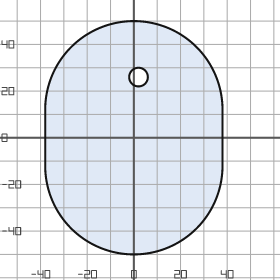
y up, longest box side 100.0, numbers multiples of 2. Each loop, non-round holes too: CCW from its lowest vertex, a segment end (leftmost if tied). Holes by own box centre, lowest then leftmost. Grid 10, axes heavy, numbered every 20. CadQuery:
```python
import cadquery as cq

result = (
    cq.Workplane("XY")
    .moveTo(-38.0, -12.0)
    .threePointArc((0.0, -50.0), (38.0, -12.0))
    .lineTo(38.0, 12.0)
    .threePointArc((0.0, 50.0), (-38.0, 12.0))
    .close()
    .moveTo(2.0, 26.0)
    .circle(4.0)
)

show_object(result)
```